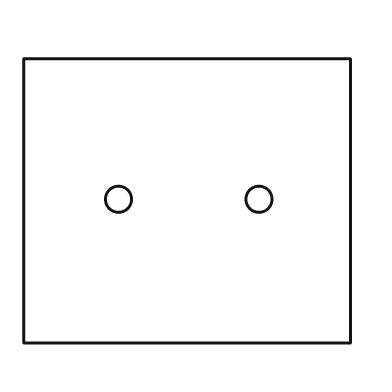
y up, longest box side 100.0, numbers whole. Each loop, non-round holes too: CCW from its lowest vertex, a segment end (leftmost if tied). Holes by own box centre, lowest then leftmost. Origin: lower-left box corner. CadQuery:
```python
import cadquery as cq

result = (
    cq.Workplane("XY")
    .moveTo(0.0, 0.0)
    .lineTo(100.0, 0.0)
    .lineTo(100.0, 87.0)
    .lineTo(0.0, 87.0)
    .close()
    .moveTo(29.0, 44.0)
    .circle(4.0)
    .moveTo(72.0, 44.0)
    .circle(4.0)
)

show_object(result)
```